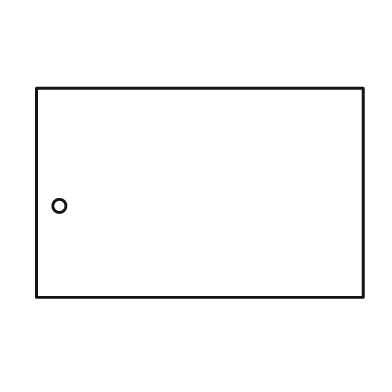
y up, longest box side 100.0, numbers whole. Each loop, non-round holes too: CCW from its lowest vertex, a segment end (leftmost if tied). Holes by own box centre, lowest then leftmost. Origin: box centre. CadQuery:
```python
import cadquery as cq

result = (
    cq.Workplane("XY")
    .moveTo(-50.0, -32.0)
    .lineTo(50.0, -32.0)
    .lineTo(50.0, 32.0)
    .lineTo(-50.0, 32.0)
    .close()
    .moveTo(-43.0, -4.0)
    .circle(2.0)
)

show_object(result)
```